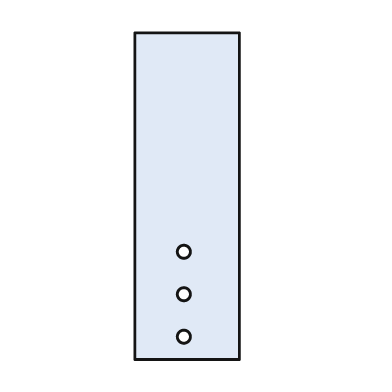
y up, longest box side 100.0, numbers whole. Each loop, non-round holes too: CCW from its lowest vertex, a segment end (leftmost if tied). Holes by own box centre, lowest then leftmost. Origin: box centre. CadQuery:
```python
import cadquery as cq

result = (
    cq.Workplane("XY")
    .moveTo(-16.0, -50.0)
    .lineTo(16.0, -50.0)
    .lineTo(16.0, 50.0)
    .lineTo(-16.0, 50.0)
    .close()
    .moveTo(-1.0, -43.0)
    .circle(2.0)
    .moveTo(-1.0, -30.0)
    .circle(2.0)
    .moveTo(-1.0, -17.0)
    .circle(2.0)
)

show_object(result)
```